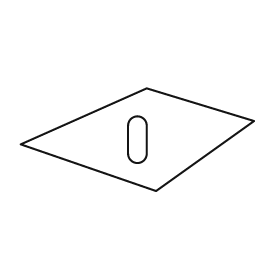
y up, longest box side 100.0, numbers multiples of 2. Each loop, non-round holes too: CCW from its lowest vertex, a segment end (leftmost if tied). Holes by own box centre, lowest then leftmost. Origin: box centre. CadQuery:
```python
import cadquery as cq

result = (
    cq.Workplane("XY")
    .moveTo(8.0, -22.0)
    .lineTo(50.0, 8.0)
    .lineTo(4.0, 22.0)
    .lineTo(-50.0, -2.0)
    .close()
    .moveTo(-4.0, -6.0)
    .threePointArc((0.0, -10.0), (4.0, -6.0))
    .lineTo(4.0, 6.0)
    .threePointArc((0.0, 10.0), (-4.0, 6.0))
    .close()
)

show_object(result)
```